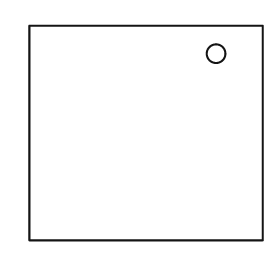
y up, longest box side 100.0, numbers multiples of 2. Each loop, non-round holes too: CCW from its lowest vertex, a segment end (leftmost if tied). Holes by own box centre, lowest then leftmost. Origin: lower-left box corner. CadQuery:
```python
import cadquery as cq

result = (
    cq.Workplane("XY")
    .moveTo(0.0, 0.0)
    .lineTo(100.0, 0.0)
    .lineTo(100.0, 92.0)
    .lineTo(0.0, 92.0)
    .close()
    .moveTo(80.0, 80.0)
    .circle(4.0)
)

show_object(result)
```